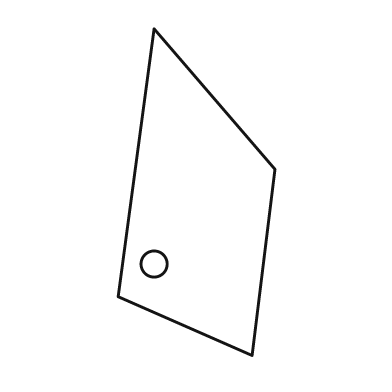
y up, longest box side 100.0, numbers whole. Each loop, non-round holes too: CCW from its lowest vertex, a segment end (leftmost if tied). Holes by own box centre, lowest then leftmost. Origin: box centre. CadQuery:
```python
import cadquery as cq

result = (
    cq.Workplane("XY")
    .moveTo(17.0, -50.0)
    .lineTo(24.0, 7.0)
    .lineTo(-13.0, 50.0)
    .lineTo(-24.0, -32.0)
    .close()
    .moveTo(-13.0, -22.0)
    .circle(4.0)
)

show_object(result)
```